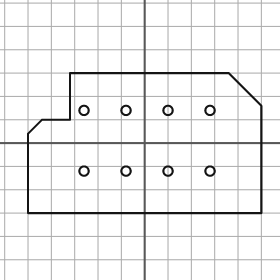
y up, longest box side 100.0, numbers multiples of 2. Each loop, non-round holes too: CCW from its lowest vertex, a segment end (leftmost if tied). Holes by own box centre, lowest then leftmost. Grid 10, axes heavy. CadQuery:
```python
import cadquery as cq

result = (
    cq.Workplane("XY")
    .moveTo(-50.0, -30.0)
    .lineTo(50.0, -30.0)
    .lineTo(50.0, 16.0)
    .lineTo(36.0, 30.0)
    .lineTo(-32.0, 30.0)
    .lineTo(-32.0, 10.0)
    .lineTo(-44.0, 10.0)
    .lineTo(-50.0, 4.0)
    .close()
    .moveTo(-26.0, -12.0)
    .circle(2.0)
    .moveTo(-8.0, -12.0)
    .circle(2.0)
    .moveTo(10.0, -12.0)
    .circle(2.0)
    .moveTo(28.0, -12.0)
    .circle(2.0)
    .moveTo(-26.0, 14.0)
    .circle(2.0)
    .moveTo(-8.0, 14.0)
    .circle(2.0)
    .moveTo(10.0, 14.0)
    .circle(2.0)
    .moveTo(28.0, 14.0)
    .circle(2.0)
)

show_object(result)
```